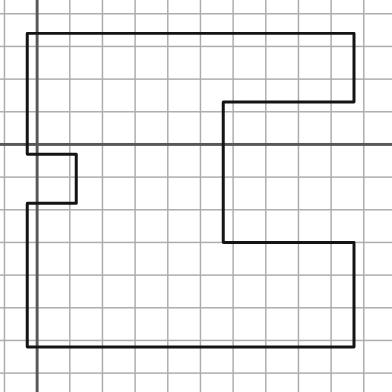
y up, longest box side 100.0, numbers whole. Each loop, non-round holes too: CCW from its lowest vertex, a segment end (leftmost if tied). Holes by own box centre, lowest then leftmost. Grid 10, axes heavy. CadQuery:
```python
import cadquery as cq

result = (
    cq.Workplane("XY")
    .moveTo(-3.0, -62.0)
    .lineTo(97.0, -62.0)
    .lineTo(97.0, -30.0)
    .lineTo(57.0, -30.0)
    .lineTo(57.0, 13.0)
    .lineTo(97.0, 13.0)
    .lineTo(97.0, 34.0)
    .lineTo(-3.0, 34.0)
    .lineTo(-3.0, -3.0)
    .lineTo(12.0, -3.0)
    .lineTo(12.0, -18.0)
    .lineTo(-3.0, -18.0)
    .close()
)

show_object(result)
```